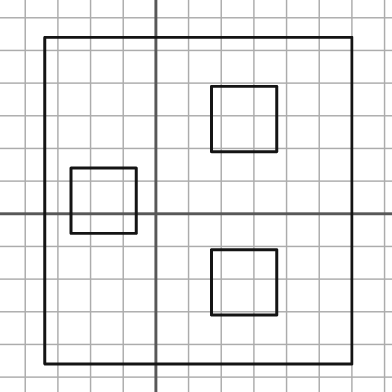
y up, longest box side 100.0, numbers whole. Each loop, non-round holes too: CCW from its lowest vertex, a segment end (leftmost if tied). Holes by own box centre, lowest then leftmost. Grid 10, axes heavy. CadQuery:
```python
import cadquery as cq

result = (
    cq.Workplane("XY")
    .moveTo(-34.0, -46.0)
    .lineTo(60.0, -46.0)
    .lineTo(60.0, 54.0)
    .lineTo(-34.0, 54.0)
    .close()
    .moveTo(17.0, -31.0)
    .lineTo(37.0, -31.0)
    .lineTo(37.0, -11.0)
    .lineTo(17.0, -11.0)
    .close()
    .moveTo(-26.0, -6.0)
    .lineTo(-6.0, -6.0)
    .lineTo(-6.0, 14.0)
    .lineTo(-26.0, 14.0)
    .close()
    .moveTo(17.0, 19.0)
    .lineTo(37.0, 19.0)
    .lineTo(37.0, 39.0)
    .lineTo(17.0, 39.0)
    .close()
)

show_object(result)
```